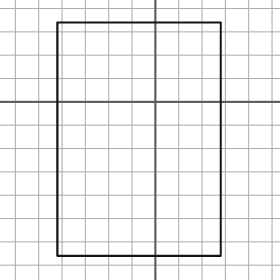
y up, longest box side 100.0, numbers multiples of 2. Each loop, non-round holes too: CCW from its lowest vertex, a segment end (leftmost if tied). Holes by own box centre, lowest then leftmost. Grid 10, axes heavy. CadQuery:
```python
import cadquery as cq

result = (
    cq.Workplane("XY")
    .moveTo(-42.0, -66.0)
    .lineTo(28.0, -66.0)
    .lineTo(28.0, 34.0)
    .lineTo(-42.0, 34.0)
    .close()
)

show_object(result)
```